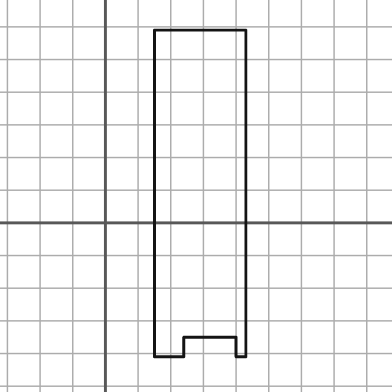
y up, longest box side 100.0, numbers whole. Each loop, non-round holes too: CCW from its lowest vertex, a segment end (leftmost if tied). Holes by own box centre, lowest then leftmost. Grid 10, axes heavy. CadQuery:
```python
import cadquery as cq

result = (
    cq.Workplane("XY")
    .moveTo(15.0, -41.0)
    .lineTo(24.0, -41.0)
    .lineTo(24.0, -35.0)
    .lineTo(40.0, -35.0)
    .lineTo(40.0, -41.0)
    .lineTo(43.0, -41.0)
    .lineTo(43.0, 59.0)
    .lineTo(15.0, 59.0)
    .close()
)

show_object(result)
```